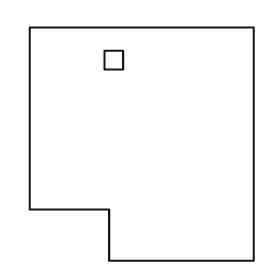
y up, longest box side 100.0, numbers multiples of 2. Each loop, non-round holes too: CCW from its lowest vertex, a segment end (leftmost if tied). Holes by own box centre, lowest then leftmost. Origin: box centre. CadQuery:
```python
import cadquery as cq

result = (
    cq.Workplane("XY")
    .moveTo(-14.0, -50.0)
    .lineTo(48.0, -50.0)
    .lineTo(48.0, 50.0)
    .lineTo(-48.0, 50.0)
    .lineTo(-48.0, -28.0)
    .lineTo(-14.0, -28.0)
    .close()
    .moveTo(-16.0, 32.0)
    .lineTo(-8.0, 32.0)
    .lineTo(-8.0, 40.0)
    .lineTo(-16.0, 40.0)
    .close()
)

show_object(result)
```